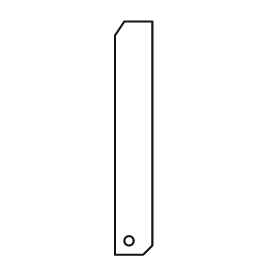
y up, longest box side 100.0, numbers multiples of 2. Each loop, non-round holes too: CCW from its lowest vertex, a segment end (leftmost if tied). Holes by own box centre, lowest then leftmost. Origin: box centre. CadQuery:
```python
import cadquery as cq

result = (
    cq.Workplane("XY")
    .moveTo(-8.0, -50.0)
    .lineTo(4.0, -50.0)
    .lineTo(8.0, -46.0)
    .lineTo(8.0, 50.0)
    .lineTo(-4.0, 50.0)
    .lineTo(-8.0, 44.0)
    .close()
    .moveTo(-2.0, -44.0)
    .circle(2.0)
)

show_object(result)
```